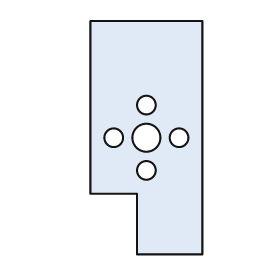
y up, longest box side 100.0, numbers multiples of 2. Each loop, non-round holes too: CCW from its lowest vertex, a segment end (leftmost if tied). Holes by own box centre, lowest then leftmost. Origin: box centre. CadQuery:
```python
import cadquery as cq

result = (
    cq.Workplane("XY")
    .moveTo(-4.0, -50.0)
    .lineTo(24.0, -50.0)
    .lineTo(24.0, 50.0)
    .lineTo(-24.0, 50.0)
    .lineTo(-24.0, -24.0)
    .lineTo(-4.0, -24.0)
    .close()
    .moveTo(0.0, -14.0)
    .circle(4.0)
    .moveTo(-14.0, 0.0)
    .circle(4.0)
    .moveTo(0.0, 0.0)
    .circle(6.0)
    .moveTo(14.0, 0.0)
    .circle(4.0)
    .moveTo(0.0, 14.0)
    .circle(4.0)
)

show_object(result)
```